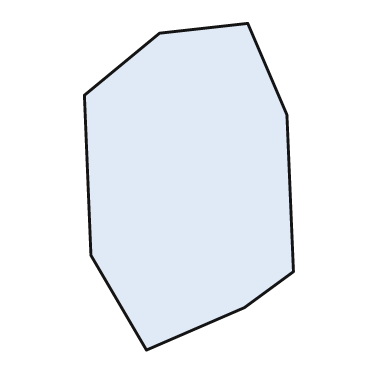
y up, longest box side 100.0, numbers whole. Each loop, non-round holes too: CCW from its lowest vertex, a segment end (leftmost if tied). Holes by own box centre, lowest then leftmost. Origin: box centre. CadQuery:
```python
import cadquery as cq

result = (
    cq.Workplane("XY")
    .moveTo(-13.0, -50.0)
    .lineTo(17.0, -37.0)
    .lineTo(32.0, -26.0)
    .lineTo(30.0, 22.0)
    .lineTo(18.0, 50.0)
    .lineTo(-9.0, 47.0)
    .lineTo(-32.0, 28.0)
    .lineTo(-30.0, -21.0)
    .close()
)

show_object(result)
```